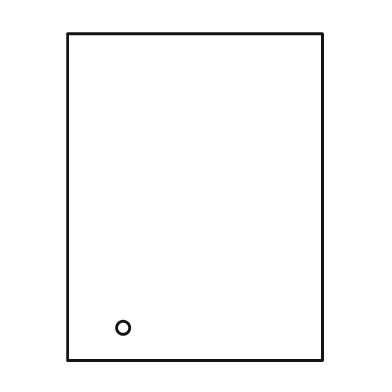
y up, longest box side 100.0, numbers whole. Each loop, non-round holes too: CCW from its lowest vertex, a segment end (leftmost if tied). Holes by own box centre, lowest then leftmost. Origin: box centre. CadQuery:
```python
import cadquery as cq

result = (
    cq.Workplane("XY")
    .moveTo(-39.0, -50.0)
    .lineTo(39.0, -50.0)
    .lineTo(39.0, 50.0)
    .lineTo(-39.0, 50.0)
    .close()
    .moveTo(-22.0, -40.0)
    .circle(2.0)
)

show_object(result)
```